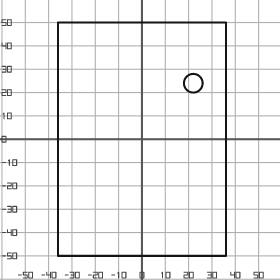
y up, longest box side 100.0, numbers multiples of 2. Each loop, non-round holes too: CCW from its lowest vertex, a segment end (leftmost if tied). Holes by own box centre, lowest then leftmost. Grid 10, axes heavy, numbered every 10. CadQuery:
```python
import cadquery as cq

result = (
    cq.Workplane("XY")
    .moveTo(-36.0, -50.0)
    .lineTo(36.0, -50.0)
    .lineTo(36.0, 50.0)
    .lineTo(-36.0, 50.0)
    .close()
    .moveTo(22.0, 24.0)
    .circle(4.0)
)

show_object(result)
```